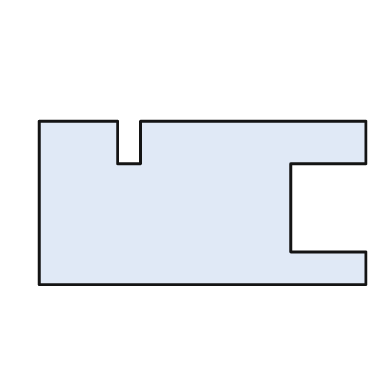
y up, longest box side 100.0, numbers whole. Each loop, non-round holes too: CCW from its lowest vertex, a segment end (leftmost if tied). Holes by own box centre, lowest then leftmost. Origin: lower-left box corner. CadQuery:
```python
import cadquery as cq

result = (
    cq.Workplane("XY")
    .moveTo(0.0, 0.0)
    .lineTo(100.0, 0.0)
    .lineTo(100.0, 10.0)
    .lineTo(77.0, 10.0)
    .lineTo(77.0, 37.0)
    .lineTo(100.0, 37.0)
    .lineTo(100.0, 50.0)
    .lineTo(31.0, 50.0)
    .lineTo(31.0, 37.0)
    .lineTo(24.0, 37.0)
    .lineTo(24.0, 50.0)
    .lineTo(0.0, 50.0)
    .close()
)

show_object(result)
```